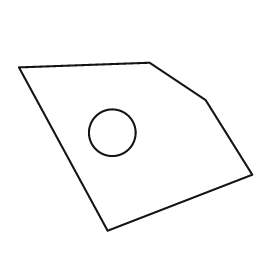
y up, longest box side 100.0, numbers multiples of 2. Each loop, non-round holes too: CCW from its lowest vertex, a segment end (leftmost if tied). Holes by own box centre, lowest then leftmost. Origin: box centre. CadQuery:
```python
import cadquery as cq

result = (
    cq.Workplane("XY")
    .moveTo(-12.0, -36.0)
    .lineTo(50.0, -12.0)
    .lineTo(30.0, 20.0)
    .lineTo(6.0, 36.0)
    .lineTo(-50.0, 34.0)
    .close()
    .moveTo(-10.0, 6.0)
    .circle(10.0)
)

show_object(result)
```